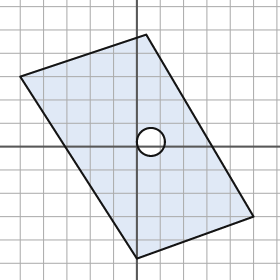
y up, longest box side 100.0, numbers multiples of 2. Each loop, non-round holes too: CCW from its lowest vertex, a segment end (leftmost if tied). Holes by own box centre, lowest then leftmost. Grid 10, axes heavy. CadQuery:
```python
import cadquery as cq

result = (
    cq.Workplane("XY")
    .moveTo(0.0, -48.0)
    .lineTo(50.0, -30.0)
    .lineTo(4.0, 48.0)
    .lineTo(-50.0, 30.0)
    .close()
    .moveTo(6.0, 2.0)
    .circle(6.0)
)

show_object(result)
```